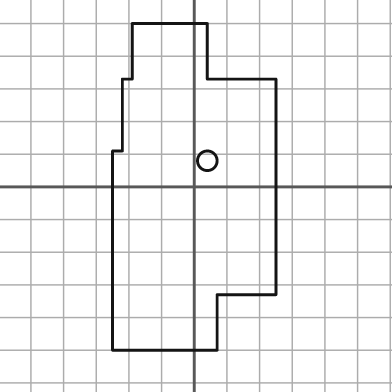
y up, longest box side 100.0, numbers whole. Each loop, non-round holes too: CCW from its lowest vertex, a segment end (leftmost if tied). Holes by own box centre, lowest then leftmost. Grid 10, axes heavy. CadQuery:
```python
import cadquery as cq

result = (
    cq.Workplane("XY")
    .moveTo(-25.0, -50.0)
    .lineTo(7.0, -50.0)
    .lineTo(7.0, -33.0)
    .lineTo(25.0, -33.0)
    .lineTo(25.0, 33.0)
    .lineTo(4.0, 33.0)
    .lineTo(4.0, 50.0)
    .lineTo(-19.0, 50.0)
    .lineTo(-19.0, 33.0)
    .lineTo(-22.0, 33.0)
    .lineTo(-22.0, 11.0)
    .lineTo(-25.0, 11.0)
    .close()
    .moveTo(4.0, 8.0)
    .circle(3.0)
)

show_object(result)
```